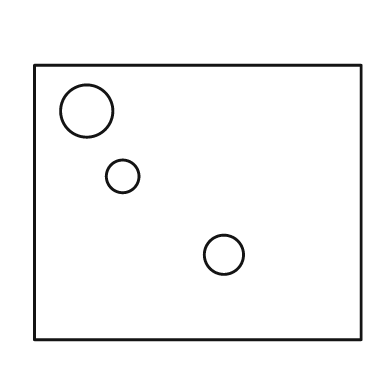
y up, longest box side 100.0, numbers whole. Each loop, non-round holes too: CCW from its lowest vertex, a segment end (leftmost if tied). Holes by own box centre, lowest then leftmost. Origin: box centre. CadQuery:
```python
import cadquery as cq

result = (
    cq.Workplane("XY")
    .moveTo(-50.0, -42.0)
    .lineTo(50.0, -42.0)
    .lineTo(50.0, 42.0)
    .lineTo(-50.0, 42.0)
    .close()
    .moveTo(8.0, -16.0)
    .circle(6.0)
    .moveTo(-23.0, 8.0)
    .circle(5.0)
    .moveTo(-34.0, 28.0)
    .circle(8.0)
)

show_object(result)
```